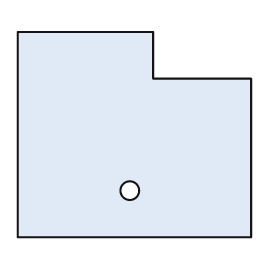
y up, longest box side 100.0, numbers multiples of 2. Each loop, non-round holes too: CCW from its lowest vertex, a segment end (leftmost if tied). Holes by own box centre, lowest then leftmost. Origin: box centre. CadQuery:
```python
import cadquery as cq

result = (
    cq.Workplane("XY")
    .moveTo(-50.0, -44.0)
    .lineTo(50.0, -44.0)
    .lineTo(50.0, 24.0)
    .lineTo(8.0, 24.0)
    .lineTo(8.0, 44.0)
    .lineTo(-50.0, 44.0)
    .close()
    .moveTo(-2.0, -24.0)
    .circle(4.0)
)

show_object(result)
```